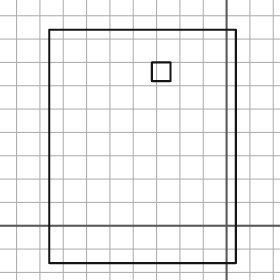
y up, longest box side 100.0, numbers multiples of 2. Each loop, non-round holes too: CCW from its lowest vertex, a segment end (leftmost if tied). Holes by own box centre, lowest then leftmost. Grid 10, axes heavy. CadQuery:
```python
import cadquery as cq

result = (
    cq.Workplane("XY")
    .moveTo(-76.0, -16.0)
    .lineTo(4.0, -16.0)
    .lineTo(4.0, 84.0)
    .lineTo(-76.0, 84.0)
    .close()
    .moveTo(-32.0, 62.0)
    .lineTo(-24.0, 62.0)
    .lineTo(-24.0, 70.0)
    .lineTo(-32.0, 70.0)
    .close()
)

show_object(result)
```